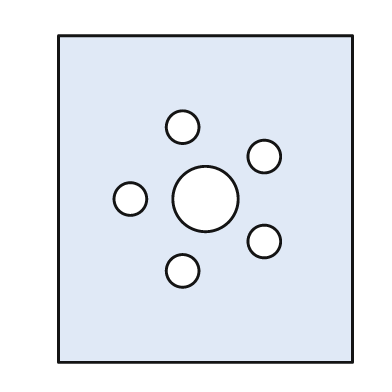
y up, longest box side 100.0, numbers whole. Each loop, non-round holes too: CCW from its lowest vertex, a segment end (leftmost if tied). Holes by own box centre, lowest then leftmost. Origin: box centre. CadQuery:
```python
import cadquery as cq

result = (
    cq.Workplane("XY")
    .moveTo(-45.0, -50.0)
    .lineTo(45.0, -50.0)
    .lineTo(45.0, 50.0)
    .lineTo(-45.0, 50.0)
    .close()
    .moveTo(-7.0, -22.0)
    .circle(5.0)
    .moveTo(18.0, -13.0)
    .circle(5.0)
    .moveTo(-23.0, 0.0)
    .circle(5.0)
    .moveTo(0.0, 0.0)
    .circle(10.0)
    .moveTo(18.0, 13.0)
    .circle(5.0)
    .moveTo(-7.0, 22.0)
    .circle(5.0)
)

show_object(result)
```